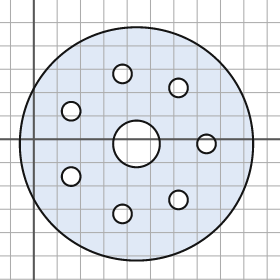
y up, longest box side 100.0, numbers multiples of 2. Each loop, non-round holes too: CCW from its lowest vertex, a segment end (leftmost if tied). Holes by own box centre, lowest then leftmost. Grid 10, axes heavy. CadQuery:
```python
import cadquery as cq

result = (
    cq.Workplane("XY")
    .moveTo(44.0, -2.0)
    .circle(50.0)
    .moveTo(38.0, -32.0)
    .circle(4.0)
    .moveTo(62.0, -26.0)
    .circle(4.0)
    .moveTo(16.0, -16.0)
    .circle(4.0)
    .moveTo(44.0, -2.0)
    .circle(10.0)
    .moveTo(74.0, -2.0)
    .circle(4.0)
    .moveTo(16.0, 12.0)
    .circle(4.0)
    .moveTo(62.0, 22.0)
    .circle(4.0)
    .moveTo(38.0, 28.0)
    .circle(4.0)
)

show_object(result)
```